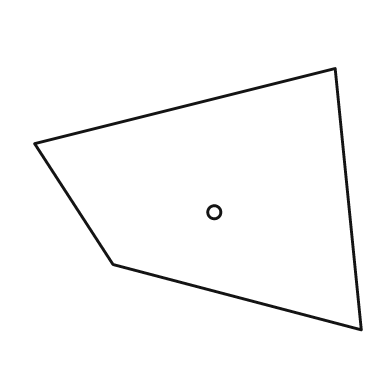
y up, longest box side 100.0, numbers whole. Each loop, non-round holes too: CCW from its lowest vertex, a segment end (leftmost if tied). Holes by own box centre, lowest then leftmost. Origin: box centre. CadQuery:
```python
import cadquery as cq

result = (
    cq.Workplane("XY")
    .moveTo(50.0, -40.0)
    .lineTo(42.0, 40.0)
    .lineTo(-50.0, 17.0)
    .lineTo(-26.0, -20.0)
    .close()
    .moveTo(5.0, -4.0)
    .circle(2.0)
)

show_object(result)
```